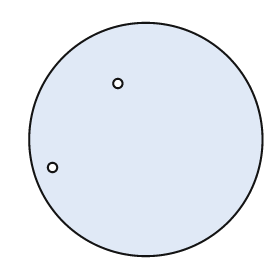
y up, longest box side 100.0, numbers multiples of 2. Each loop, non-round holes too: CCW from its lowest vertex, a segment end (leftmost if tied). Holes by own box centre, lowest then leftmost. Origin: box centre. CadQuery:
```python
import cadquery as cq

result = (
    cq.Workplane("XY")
    .moveTo(0.0, 0.0)
    .circle(50.0)
    .moveTo(-40.0, -12.0)
    .circle(2.0)
    .moveTo(-12.0, 24.0)
    .circle(2.0)
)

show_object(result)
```